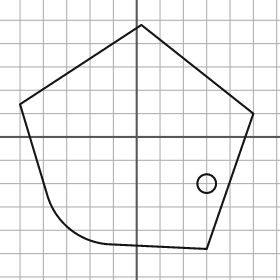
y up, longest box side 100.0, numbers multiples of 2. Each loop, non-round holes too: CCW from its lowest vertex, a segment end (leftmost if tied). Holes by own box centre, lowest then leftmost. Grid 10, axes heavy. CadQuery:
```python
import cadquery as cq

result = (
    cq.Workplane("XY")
    .moveTo(30.0, -48.0)
    .lineTo(50.0, 10.0)
    .lineTo(2.0, 48.0)
    .lineTo(-50.0, 14.0)
    .lineTo(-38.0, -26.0)
    .threePointArc((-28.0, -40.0), (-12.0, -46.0))
    .close()
    .moveTo(30.0, -20.0)
    .circle(4.0)
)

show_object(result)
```